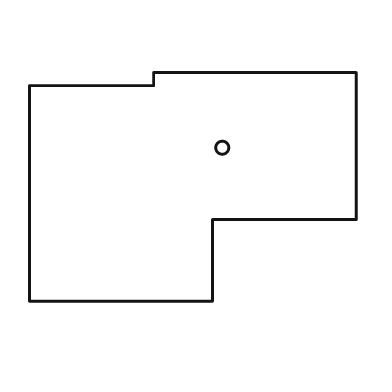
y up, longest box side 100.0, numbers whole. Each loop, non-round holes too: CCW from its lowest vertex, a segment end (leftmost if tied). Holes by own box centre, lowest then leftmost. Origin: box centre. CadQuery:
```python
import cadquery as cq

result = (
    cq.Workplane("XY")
    .moveTo(-50.0, -35.0)
    .lineTo(6.0, -35.0)
    .lineTo(6.0, -10.0)
    .lineTo(50.0, -10.0)
    .lineTo(50.0, 35.0)
    .lineTo(-12.0, 35.0)
    .lineTo(-12.0, 31.0)
    .lineTo(-50.0, 31.0)
    .close()
    .moveTo(9.0, 12.0)
    .circle(2.0)
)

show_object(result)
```